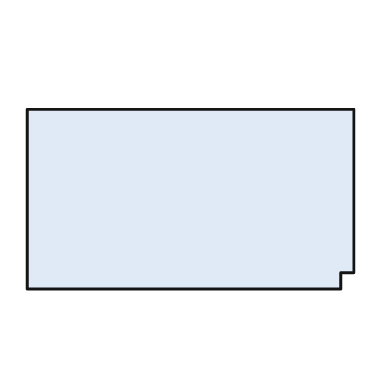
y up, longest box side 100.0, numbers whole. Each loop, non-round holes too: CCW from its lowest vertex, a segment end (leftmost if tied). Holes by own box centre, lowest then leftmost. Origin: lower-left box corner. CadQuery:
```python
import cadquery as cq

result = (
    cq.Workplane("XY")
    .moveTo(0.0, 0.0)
    .lineTo(96.0, 0.0)
    .lineTo(96.0, 5.0)
    .lineTo(100.0, 5.0)
    .lineTo(100.0, 55.0)
    .lineTo(0.0, 55.0)
    .close()
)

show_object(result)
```